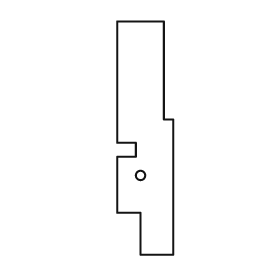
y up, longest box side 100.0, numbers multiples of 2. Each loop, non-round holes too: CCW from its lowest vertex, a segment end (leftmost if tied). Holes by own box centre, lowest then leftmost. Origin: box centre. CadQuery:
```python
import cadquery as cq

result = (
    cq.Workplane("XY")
    .moveTo(-2.0, -50.0)
    .lineTo(12.0, -50.0)
    .lineTo(12.0, 8.0)
    .lineTo(8.0, 8.0)
    .lineTo(8.0, 50.0)
    .lineTo(-12.0, 50.0)
    .lineTo(-12.0, -2.0)
    .lineTo(-4.0, -2.0)
    .lineTo(-4.0, -8.0)
    .lineTo(-12.0, -8.0)
    .lineTo(-12.0, -32.0)
    .lineTo(-2.0, -32.0)
    .close()
    .moveTo(-2.0, -16.0)
    .circle(2.0)
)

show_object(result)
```